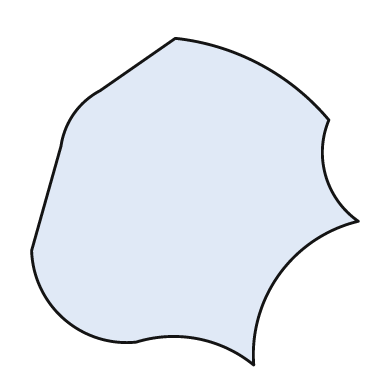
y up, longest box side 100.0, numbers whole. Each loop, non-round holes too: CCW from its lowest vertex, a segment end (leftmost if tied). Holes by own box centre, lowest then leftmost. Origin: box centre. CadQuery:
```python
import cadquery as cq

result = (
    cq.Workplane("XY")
    .moveTo(18.0, -50.0)
    .threePointArc((26.0, -22.0), (50.0, -6.0))
    .threePointArc((40.0, 8.0), (41.0, 25.0))
    .threePointArc((20.0, 42.0), (-6.0, 50.0))
    .lineTo(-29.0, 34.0)
    .threePointArc((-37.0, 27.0), (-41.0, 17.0))
    .lineTo(-50.0, -15.0)
    .threePointArc((-40.0, -36.0), (-18.0, -43.0))
    .threePointArc((1.0, -42.0), (18.0, -50.0))
    .close()
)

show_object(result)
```